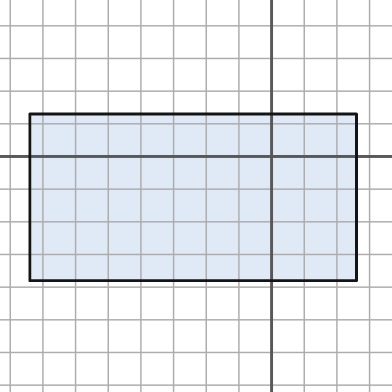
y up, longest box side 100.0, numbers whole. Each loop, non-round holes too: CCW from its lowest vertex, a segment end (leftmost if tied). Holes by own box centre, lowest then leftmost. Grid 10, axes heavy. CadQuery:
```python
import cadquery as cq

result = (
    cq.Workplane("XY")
    .moveTo(-74.0, -38.0)
    .lineTo(26.0, -38.0)
    .lineTo(26.0, 13.0)
    .lineTo(-74.0, 13.0)
    .close()
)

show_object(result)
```